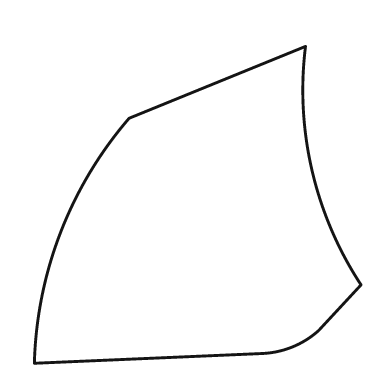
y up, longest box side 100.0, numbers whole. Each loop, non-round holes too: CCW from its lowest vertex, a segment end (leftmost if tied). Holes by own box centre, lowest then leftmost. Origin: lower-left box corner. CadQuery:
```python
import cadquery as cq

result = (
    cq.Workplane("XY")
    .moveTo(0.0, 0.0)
    .lineTo(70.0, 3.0)
    .threePointArc((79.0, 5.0), (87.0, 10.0))
    .lineTo(100.0, 24.0)
    .threePointArc((85.0, 59.0), (83.0, 97.0))
    .lineTo(29.0, 75.0)
    .threePointArc((8.0, 40.0), (0.0, 0.0))
    .close()
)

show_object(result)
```